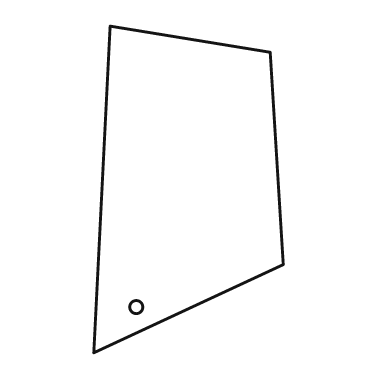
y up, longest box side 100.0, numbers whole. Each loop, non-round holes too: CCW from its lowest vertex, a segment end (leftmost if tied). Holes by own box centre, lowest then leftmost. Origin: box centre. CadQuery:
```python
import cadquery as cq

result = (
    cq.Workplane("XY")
    .moveTo(-29.0, -50.0)
    .lineTo(29.0, -23.0)
    .lineTo(25.0, 42.0)
    .lineTo(-24.0, 50.0)
    .close()
    .moveTo(-16.0, -36.0)
    .circle(2.0)
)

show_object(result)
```